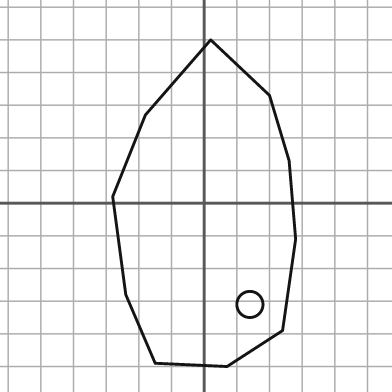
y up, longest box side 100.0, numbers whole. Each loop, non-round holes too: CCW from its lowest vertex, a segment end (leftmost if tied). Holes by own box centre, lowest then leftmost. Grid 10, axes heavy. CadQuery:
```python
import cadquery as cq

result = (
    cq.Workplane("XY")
    .moveTo(7.0, -50.0)
    .lineTo(24.0, -39.0)
    .lineTo(28.0, -11.0)
    .lineTo(26.0, 13.0)
    .lineTo(20.0, 33.0)
    .lineTo(2.0, 50.0)
    .lineTo(-18.0, 27.0)
    .lineTo(-28.0, 2.0)
    .lineTo(-24.0, -28.0)
    .lineTo(-15.0, -49.0)
    .close()
    .moveTo(14.0, -31.0)
    .circle(4.0)
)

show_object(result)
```